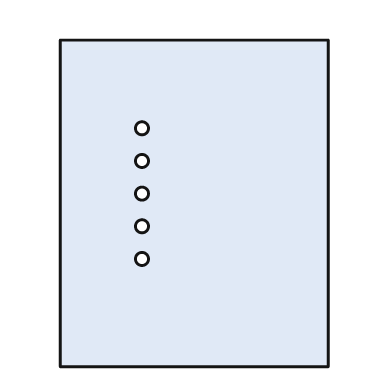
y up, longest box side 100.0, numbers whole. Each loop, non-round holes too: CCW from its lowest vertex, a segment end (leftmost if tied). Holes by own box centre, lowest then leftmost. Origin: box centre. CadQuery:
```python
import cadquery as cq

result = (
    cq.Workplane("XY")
    .moveTo(-41.0, -50.0)
    .lineTo(41.0, -50.0)
    .lineTo(41.0, 50.0)
    .lineTo(-41.0, 50.0)
    .close()
    .moveTo(-16.0, -17.0)
    .circle(2.0)
    .moveTo(-16.0, -7.0)
    .circle(2.0)
    .moveTo(-16.0, 3.0)
    .circle(2.0)
    .moveTo(-16.0, 13.0)
    .circle(2.0)
    .moveTo(-16.0, 23.0)
    .circle(2.0)
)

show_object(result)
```